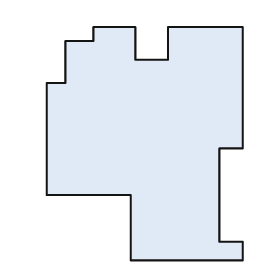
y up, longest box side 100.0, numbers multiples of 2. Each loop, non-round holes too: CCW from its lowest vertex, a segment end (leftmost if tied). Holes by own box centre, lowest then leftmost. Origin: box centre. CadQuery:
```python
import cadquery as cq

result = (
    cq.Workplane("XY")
    .moveTo(-6.0, -50.0)
    .lineTo(42.0, -50.0)
    .lineTo(42.0, -42.0)
    .lineTo(32.0, -42.0)
    .lineTo(32.0, -2.0)
    .lineTo(42.0, -2.0)
    .lineTo(42.0, 50.0)
    .lineTo(10.0, 50.0)
    .lineTo(10.0, 36.0)
    .lineTo(-4.0, 36.0)
    .lineTo(-4.0, 50.0)
    .lineTo(-22.0, 50.0)
    .lineTo(-22.0, 44.0)
    .lineTo(-34.0, 44.0)
    .lineTo(-34.0, 26.0)
    .lineTo(-42.0, 26.0)
    .lineTo(-42.0, -22.0)
    .lineTo(-6.0, -22.0)
    .close()
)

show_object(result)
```